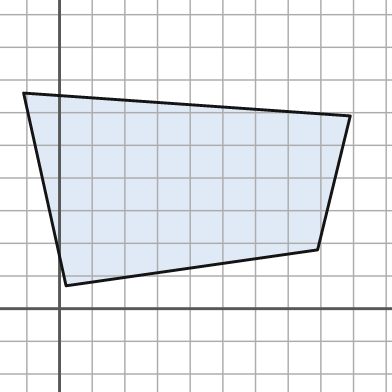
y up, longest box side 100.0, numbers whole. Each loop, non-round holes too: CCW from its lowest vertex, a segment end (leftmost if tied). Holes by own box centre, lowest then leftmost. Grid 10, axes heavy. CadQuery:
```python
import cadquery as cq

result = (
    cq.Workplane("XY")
    .moveTo(2.0, 7.0)
    .lineTo(79.0, 18.0)
    .lineTo(89.0, 59.0)
    .lineTo(-11.0, 66.0)
    .close()
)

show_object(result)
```